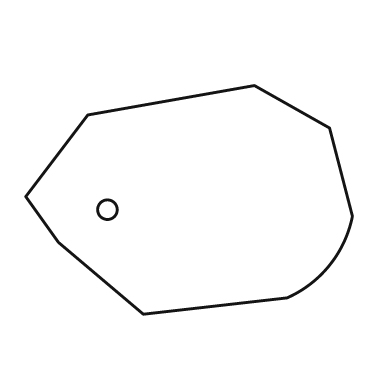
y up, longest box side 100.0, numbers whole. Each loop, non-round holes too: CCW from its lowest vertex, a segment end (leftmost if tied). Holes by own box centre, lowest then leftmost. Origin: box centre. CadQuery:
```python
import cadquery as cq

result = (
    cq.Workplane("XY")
    .moveTo(-14.0, -35.0)
    .lineTo(30.0, -30.0)
    .threePointArc((43.0, -20.0), (50.0, -5.0))
    .lineTo(43.0, 22.0)
    .lineTo(20.0, 35.0)
    .lineTo(-31.0, 26.0)
    .lineTo(-50.0, 1.0)
    .lineTo(-40.0, -13.0)
    .close()
    .moveTo(-25.0, -3.0)
    .circle(3.0)
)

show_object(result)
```